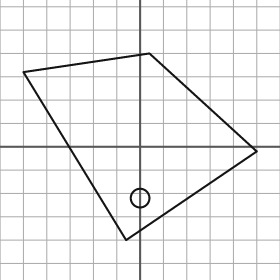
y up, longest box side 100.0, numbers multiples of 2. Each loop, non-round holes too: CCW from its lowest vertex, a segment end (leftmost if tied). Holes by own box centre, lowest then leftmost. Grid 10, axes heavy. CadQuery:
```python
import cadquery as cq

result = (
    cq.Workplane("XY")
    .moveTo(-6.0, -40.0)
    .lineTo(50.0, -2.0)
    .lineTo(4.0, 40.0)
    .lineTo(-50.0, 32.0)
    .close()
    .moveTo(0.0, -22.0)
    .circle(4.0)
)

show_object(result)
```